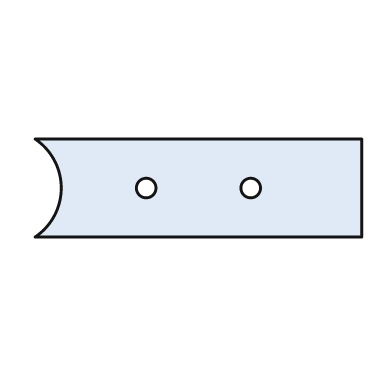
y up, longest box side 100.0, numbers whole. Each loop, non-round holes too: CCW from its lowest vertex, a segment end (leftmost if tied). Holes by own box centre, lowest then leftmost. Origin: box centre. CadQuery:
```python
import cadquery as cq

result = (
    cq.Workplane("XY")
    .moveTo(-50.0, -15.0)
    .lineTo(50.0, -15.0)
    .lineTo(50.0, 15.0)
    .lineTo(-50.0, 15.0)
    .threePointArc((-42.0, 0.0), (-50.0, -15.0))
    .close()
    .moveTo(-16.0, 0.0)
    .circle(3.0)
    .moveTo(16.0, 0.0)
    .circle(3.0)
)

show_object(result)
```